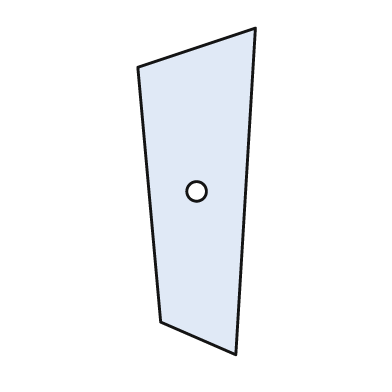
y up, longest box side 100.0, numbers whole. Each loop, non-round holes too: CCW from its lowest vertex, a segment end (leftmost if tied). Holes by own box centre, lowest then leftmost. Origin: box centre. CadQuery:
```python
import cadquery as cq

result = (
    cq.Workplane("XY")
    .moveTo(12.0, -50.0)
    .lineTo(18.0, 50.0)
    .lineTo(-18.0, 38.0)
    .lineTo(-11.0, -40.0)
    .close()
    .moveTo(0.0, 0.0)
    .circle(3.0)
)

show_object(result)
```